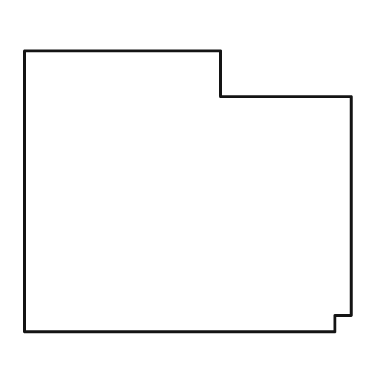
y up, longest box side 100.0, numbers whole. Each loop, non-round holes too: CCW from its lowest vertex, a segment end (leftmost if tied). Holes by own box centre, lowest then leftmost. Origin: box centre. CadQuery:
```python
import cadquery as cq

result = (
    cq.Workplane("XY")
    .moveTo(-50.0, -43.0)
    .lineTo(45.0, -43.0)
    .lineTo(45.0, -38.0)
    .lineTo(50.0, -38.0)
    .lineTo(50.0, 29.0)
    .lineTo(10.0, 29.0)
    .lineTo(10.0, 43.0)
    .lineTo(-50.0, 43.0)
    .close()
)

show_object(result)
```